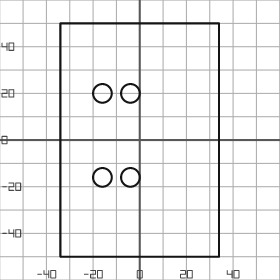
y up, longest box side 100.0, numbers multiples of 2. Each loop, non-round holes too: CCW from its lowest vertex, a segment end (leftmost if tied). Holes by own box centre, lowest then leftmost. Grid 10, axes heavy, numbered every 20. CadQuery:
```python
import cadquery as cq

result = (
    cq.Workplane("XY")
    .moveTo(-34.0, -50.0)
    .lineTo(34.0, -50.0)
    .lineTo(34.0, 50.0)
    .lineTo(-34.0, 50.0)
    .close()
    .moveTo(-16.0, -16.0)
    .circle(4.0)
    .moveTo(-4.0, -16.0)
    .circle(4.0)
    .moveTo(-16.0, 20.0)
    .circle(4.0)
    .moveTo(-4.0, 20.0)
    .circle(4.0)
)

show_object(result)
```